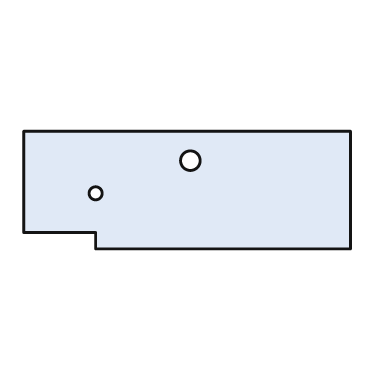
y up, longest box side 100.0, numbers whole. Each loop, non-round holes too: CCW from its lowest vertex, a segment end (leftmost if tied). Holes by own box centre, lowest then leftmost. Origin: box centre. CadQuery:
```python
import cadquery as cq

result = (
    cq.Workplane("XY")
    .moveTo(-28.0, -18.0)
    .lineTo(50.0, -18.0)
    .lineTo(50.0, 18.0)
    .lineTo(-50.0, 18.0)
    .lineTo(-50.0, -13.0)
    .lineTo(-28.0, -13.0)
    .close()
    .moveTo(-28.0, -1.0)
    .circle(2.0)
    .moveTo(1.0, 9.0)
    .circle(3.0)
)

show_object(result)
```